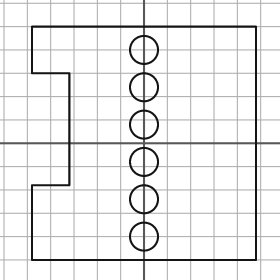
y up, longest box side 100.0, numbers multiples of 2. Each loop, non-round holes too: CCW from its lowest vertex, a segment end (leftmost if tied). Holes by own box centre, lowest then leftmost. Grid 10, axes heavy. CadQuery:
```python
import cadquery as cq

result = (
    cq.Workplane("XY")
    .moveTo(-48.0, -50.0)
    .lineTo(48.0, -50.0)
    .lineTo(48.0, 50.0)
    .lineTo(-48.0, 50.0)
    .lineTo(-48.0, 30.0)
    .lineTo(-32.0, 30.0)
    .lineTo(-32.0, -18.0)
    .lineTo(-48.0, -18.0)
    .close()
    .moveTo(0.0, -40.0)
    .circle(6.0)
    .moveTo(0.0, -24.0)
    .circle(6.0)
    .moveTo(0.0, -8.0)
    .circle(6.0)
    .moveTo(0.0, 8.0)
    .circle(6.0)
    .moveTo(0.0, 24.0)
    .circle(6.0)
    .moveTo(0.0, 40.0)
    .circle(6.0)
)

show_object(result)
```